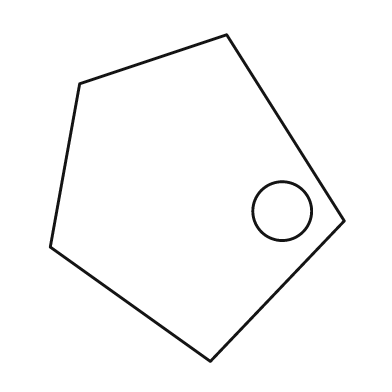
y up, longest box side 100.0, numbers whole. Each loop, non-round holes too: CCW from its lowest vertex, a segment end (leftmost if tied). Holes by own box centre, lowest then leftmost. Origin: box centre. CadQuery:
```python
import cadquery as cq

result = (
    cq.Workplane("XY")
    .moveTo(4.0, -50.0)
    .lineTo(45.0, -7.0)
    .lineTo(9.0, 50.0)
    .lineTo(-36.0, 35.0)
    .lineTo(-45.0, -15.0)
    .close()
    .moveTo(26.0, -4.0)
    .circle(9.0)
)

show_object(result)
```